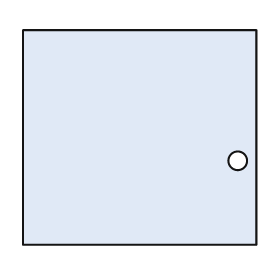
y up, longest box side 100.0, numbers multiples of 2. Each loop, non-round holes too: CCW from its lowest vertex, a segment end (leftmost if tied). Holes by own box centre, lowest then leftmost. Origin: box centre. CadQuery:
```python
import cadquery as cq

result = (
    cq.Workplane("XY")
    .moveTo(-50.0, -46.0)
    .lineTo(50.0, -46.0)
    .lineTo(50.0, 46.0)
    .lineTo(-50.0, 46.0)
    .close()
    .moveTo(42.0, -10.0)
    .circle(4.0)
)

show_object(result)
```